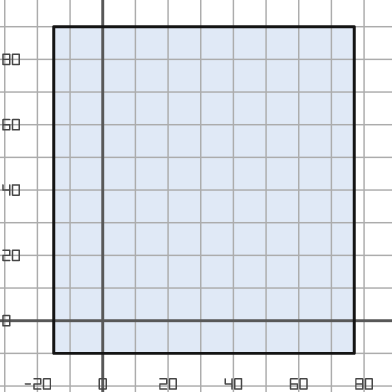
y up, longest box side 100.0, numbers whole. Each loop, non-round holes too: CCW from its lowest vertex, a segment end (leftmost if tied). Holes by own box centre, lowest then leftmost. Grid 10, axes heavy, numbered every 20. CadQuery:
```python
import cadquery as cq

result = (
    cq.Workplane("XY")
    .moveTo(-15.0, -10.0)
    .lineTo(77.0, -10.0)
    .lineTo(77.0, 90.0)
    .lineTo(-15.0, 90.0)
    .close()
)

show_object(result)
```